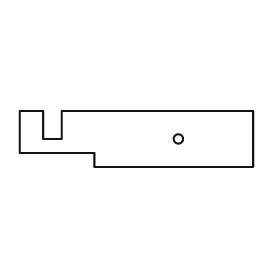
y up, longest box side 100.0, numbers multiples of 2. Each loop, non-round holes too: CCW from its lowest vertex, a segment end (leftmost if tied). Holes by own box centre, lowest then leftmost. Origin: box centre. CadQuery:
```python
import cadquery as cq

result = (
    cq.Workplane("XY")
    .moveTo(-18.0, -12.0)
    .lineTo(50.0, -12.0)
    .lineTo(50.0, 12.0)
    .lineTo(-32.0, 12.0)
    .lineTo(-32.0, 0.0)
    .lineTo(-40.0, 0.0)
    .lineTo(-40.0, 12.0)
    .lineTo(-50.0, 12.0)
    .lineTo(-50.0, -6.0)
    .lineTo(-18.0, -6.0)
    .close()
    .moveTo(18.0, 0.0)
    .circle(2.0)
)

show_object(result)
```